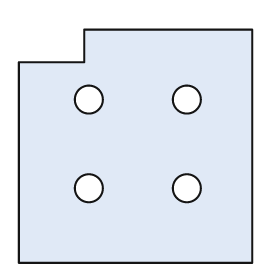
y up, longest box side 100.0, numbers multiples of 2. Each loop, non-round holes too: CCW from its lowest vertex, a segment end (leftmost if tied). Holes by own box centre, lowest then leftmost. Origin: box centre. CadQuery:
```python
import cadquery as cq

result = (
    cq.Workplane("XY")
    .moveTo(-50.0, -50.0)
    .lineTo(50.0, -50.0)
    .lineTo(50.0, 50.0)
    .lineTo(-22.0, 50.0)
    .lineTo(-22.0, 36.0)
    .lineTo(-50.0, 36.0)
    .close()
    .moveTo(-20.0, -18.0)
    .circle(6.0)
    .moveTo(22.0, -18.0)
    .circle(6.0)
    .moveTo(-20.0, 20.0)
    .circle(6.0)
    .moveTo(22.0, 20.0)
    .circle(6.0)
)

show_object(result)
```